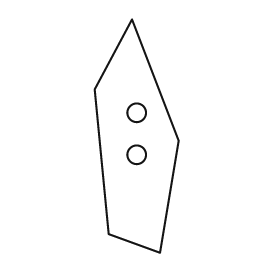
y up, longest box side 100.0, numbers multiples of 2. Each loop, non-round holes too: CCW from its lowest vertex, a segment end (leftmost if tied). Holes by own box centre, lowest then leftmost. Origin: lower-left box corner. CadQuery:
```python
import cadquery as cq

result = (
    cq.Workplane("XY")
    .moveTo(28.0, 0.0)
    .lineTo(36.0, 48.0)
    .lineTo(16.0, 100.0)
    .lineTo(0.0, 70.0)
    .lineTo(6.0, 8.0)
    .close()
    .moveTo(18.0, 42.0)
    .circle(4.0)
    .moveTo(18.0, 60.0)
    .circle(4.0)
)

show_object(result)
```